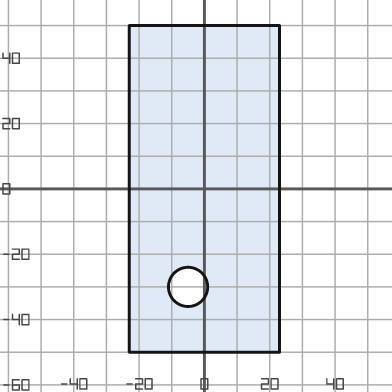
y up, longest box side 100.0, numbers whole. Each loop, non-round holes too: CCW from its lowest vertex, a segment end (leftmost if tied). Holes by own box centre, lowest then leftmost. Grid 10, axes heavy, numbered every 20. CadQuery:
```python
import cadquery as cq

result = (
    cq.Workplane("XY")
    .moveTo(-23.0, -50.0)
    .lineTo(23.0, -50.0)
    .lineTo(23.0, 50.0)
    .lineTo(-23.0, 50.0)
    .close()
    .moveTo(-5.0, -30.0)
    .circle(6.0)
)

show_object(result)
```